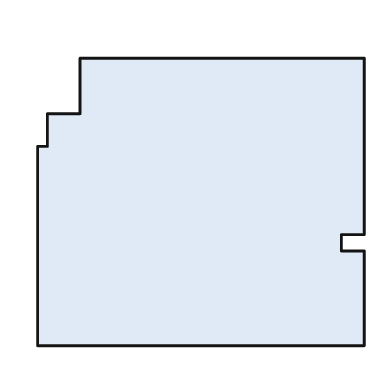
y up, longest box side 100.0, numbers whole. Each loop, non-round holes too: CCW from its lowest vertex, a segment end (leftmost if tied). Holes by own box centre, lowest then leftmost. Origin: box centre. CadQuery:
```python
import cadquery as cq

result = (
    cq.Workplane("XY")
    .moveTo(-50.0, -44.0)
    .lineTo(50.0, -44.0)
    .lineTo(50.0, -15.0)
    .lineTo(43.0, -15.0)
    .lineTo(43.0, -10.0)
    .lineTo(50.0, -10.0)
    .lineTo(50.0, 44.0)
    .lineTo(-37.0, 44.0)
    .lineTo(-37.0, 27.0)
    .lineTo(-47.0, 27.0)
    .lineTo(-47.0, 17.0)
    .lineTo(-50.0, 17.0)
    .close()
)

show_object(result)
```